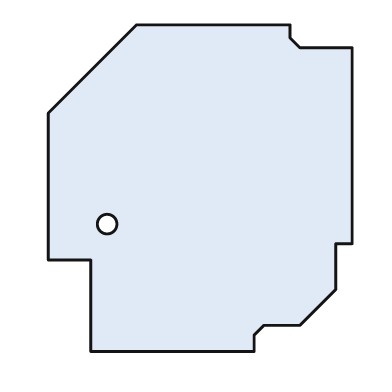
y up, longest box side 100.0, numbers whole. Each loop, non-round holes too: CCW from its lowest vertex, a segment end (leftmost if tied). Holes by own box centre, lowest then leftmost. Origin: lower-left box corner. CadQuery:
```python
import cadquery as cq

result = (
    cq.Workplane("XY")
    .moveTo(13.0, 0.0)
    .lineTo(63.0, 0.0)
    .lineTo(63.0, 5.0)
    .lineTo(66.0, 8.0)
    .lineTo(77.0, 8.0)
    .lineTo(88.0, 19.0)
    .lineTo(88.0, 33.0)
    .lineTo(93.0, 33.0)
    .lineTo(93.0, 93.0)
    .lineTo(77.0, 93.0)
    .lineTo(74.0, 96.0)
    .lineTo(74.0, 100.0)
    .lineTo(27.0, 100.0)
    .lineTo(0.0, 73.0)
    .lineTo(0.0, 28.0)
    .lineTo(13.0, 28.0)
    .close()
    .moveTo(18.0, 39.0)
    .circle(3.0)
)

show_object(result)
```